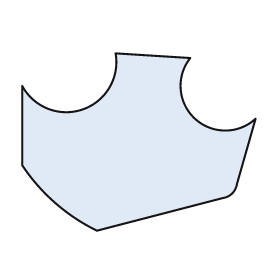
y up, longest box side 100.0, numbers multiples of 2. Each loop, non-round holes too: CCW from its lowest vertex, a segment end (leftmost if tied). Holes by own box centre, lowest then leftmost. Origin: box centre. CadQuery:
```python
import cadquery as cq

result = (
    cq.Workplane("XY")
    .moveTo(-18.0, -38.0)
    .lineTo(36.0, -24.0)
    .threePointArc((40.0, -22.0), (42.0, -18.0))
    .lineTo(50.0, 10.0)
    .threePointArc((24.0, 10.0), (22.0, 36.0))
    .lineTo(-10.0, 38.0)
    .threePointArc((-24.0, 14.0), (-50.0, 24.0))
    .lineTo(-50.0, -10.0)
    .threePointArc((-36.0, -26.0), (-18.0, -38.0))
    .close()
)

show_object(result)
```